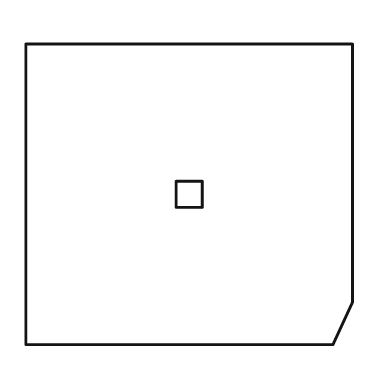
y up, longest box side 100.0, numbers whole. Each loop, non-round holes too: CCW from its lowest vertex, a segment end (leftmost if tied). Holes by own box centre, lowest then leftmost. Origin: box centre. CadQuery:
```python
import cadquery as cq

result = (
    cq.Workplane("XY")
    .moveTo(-50.0, -46.0)
    .lineTo(44.0, -46.0)
    .lineTo(50.0, -33.0)
    .lineTo(50.0, 46.0)
    .lineTo(-50.0, 46.0)
    .close()
    .moveTo(-4.0, -4.0)
    .lineTo(4.0, -4.0)
    .lineTo(4.0, 4.0)
    .lineTo(-4.0, 4.0)
    .close()
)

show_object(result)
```